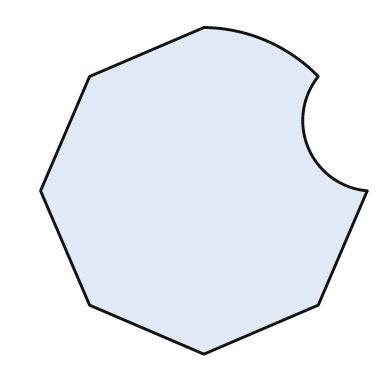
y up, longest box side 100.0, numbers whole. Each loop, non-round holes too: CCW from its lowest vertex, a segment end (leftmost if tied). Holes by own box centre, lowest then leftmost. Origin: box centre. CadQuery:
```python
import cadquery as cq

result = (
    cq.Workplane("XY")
    .moveTo(0.0, -50.0)
    .lineTo(35.0, -35.0)
    .lineTo(50.0, 0.0)
    .threePointArc((32.0, 13.0), (35.0, 35.0))
    .threePointArc((19.0, 46.0), (0.0, 50.0))
    .lineTo(-35.0, 35.0)
    .lineTo(-50.0, 0.0)
    .lineTo(-35.0, -35.0)
    .close()
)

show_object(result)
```